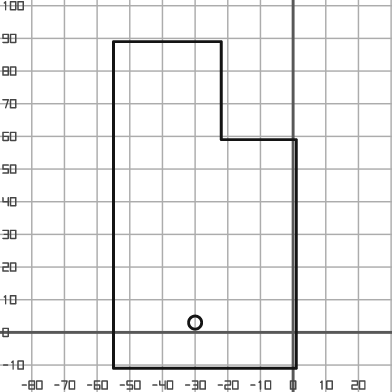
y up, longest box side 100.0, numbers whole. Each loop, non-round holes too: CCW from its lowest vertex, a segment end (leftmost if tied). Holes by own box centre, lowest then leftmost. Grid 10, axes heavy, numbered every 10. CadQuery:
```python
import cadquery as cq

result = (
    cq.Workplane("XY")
    .moveTo(-55.0, -11.0)
    .lineTo(1.0, -11.0)
    .lineTo(1.0, 59.0)
    .lineTo(-22.0, 59.0)
    .lineTo(-22.0, 89.0)
    .lineTo(-55.0, 89.0)
    .close()
    .moveTo(-30.0, 3.0)
    .circle(2.0)
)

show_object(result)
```